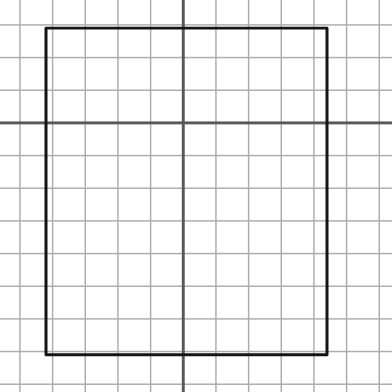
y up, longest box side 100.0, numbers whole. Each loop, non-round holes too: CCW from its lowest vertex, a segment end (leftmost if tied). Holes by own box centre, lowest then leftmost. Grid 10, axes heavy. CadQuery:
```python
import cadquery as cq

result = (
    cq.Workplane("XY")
    .moveTo(-42.0, -71.0)
    .lineTo(44.0, -71.0)
    .lineTo(44.0, 29.0)
    .lineTo(-42.0, 29.0)
    .close()
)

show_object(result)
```